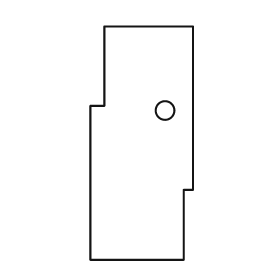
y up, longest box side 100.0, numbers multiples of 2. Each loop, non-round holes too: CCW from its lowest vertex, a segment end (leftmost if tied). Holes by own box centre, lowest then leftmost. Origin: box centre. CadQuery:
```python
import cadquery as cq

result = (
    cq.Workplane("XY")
    .moveTo(-22.0, -50.0)
    .lineTo(18.0, -50.0)
    .lineTo(18.0, -20.0)
    .lineTo(22.0, -20.0)
    .lineTo(22.0, 50.0)
    .lineTo(-16.0, 50.0)
    .lineTo(-16.0, 16.0)
    .lineTo(-22.0, 16.0)
    .close()
    .moveTo(10.0, 14.0)
    .circle(4.0)
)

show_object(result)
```